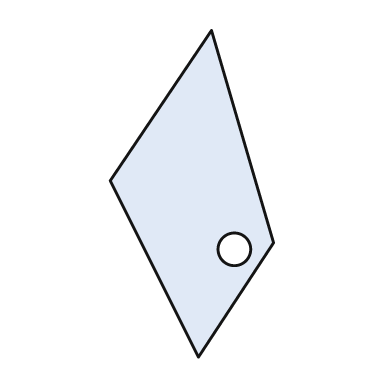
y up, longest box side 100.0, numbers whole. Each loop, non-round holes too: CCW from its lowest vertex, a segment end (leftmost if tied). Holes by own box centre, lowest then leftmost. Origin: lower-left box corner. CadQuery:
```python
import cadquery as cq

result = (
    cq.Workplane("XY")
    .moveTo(27.0, 0.0)
    .lineTo(50.0, 35.0)
    .lineTo(31.0, 100.0)
    .lineTo(0.0, 54.0)
    .close()
    .moveTo(38.0, 33.0)
    .circle(5.0)
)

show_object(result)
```